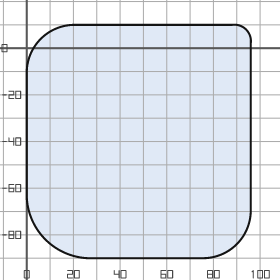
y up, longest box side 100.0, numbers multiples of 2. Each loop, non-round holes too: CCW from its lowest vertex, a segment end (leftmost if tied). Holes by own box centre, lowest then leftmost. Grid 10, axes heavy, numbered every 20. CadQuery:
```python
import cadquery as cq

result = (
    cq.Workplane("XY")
    .moveTo(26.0, -90.0)
    .lineTo(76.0, -90.0)
    .threePointArc((90.0, -84.0), (96.0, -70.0))
    .lineTo(96.0, 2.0)
    .threePointArc((94.0, 8.0), (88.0, 10.0))
    .lineTo(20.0, 10.0)
    .threePointArc((6.0, 4.0), (0.0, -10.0))
    .lineTo(0.0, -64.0)
    .threePointArc((8.0, -82.0), (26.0, -90.0))
    .close()
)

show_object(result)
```